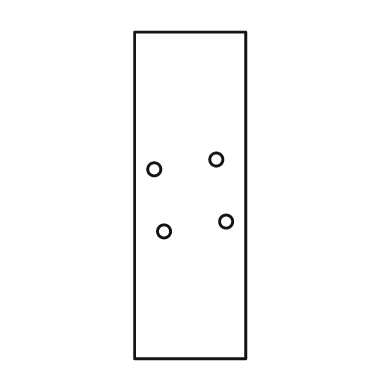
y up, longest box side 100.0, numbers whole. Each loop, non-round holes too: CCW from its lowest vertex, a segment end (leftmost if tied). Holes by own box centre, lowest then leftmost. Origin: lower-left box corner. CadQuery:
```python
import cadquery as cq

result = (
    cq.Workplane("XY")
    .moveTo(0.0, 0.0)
    .lineTo(34.0, 0.0)
    .lineTo(34.0, 100.0)
    .lineTo(0.0, 100.0)
    .close()
    .moveTo(9.0, 39.0)
    .circle(2.0)
    .moveTo(28.0, 42.0)
    .circle(2.0)
    .moveTo(6.0, 58.0)
    .circle(2.0)
    .moveTo(25.0, 61.0)
    .circle(2.0)
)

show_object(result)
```